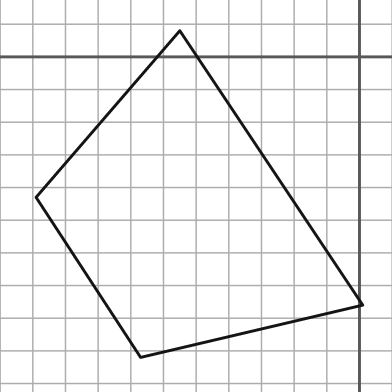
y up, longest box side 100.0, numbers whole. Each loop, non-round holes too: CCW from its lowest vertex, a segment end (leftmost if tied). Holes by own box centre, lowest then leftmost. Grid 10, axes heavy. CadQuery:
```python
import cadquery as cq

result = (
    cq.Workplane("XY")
    .moveTo(-67.0, -92.0)
    .lineTo(1.0, -76.0)
    .lineTo(-55.0, 8.0)
    .lineTo(-99.0, -43.0)
    .close()
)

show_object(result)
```